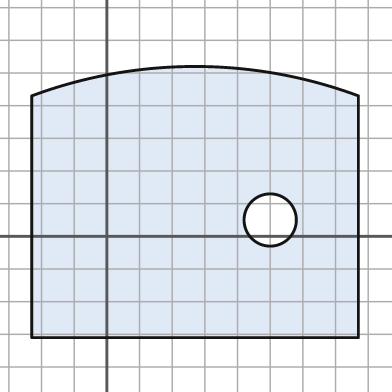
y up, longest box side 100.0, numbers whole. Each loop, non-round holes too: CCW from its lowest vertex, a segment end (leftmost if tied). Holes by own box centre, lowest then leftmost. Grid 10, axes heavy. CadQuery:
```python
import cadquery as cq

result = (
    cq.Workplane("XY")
    .moveTo(-23.0, -31.0)
    .lineTo(77.0, -31.0)
    .lineTo(77.0, 43.0)
    .threePointArc((27.0, 52.0), (-23.0, 43.0))
    .close()
    .moveTo(50.0, 5.0)
    .circle(8.0)
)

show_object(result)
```